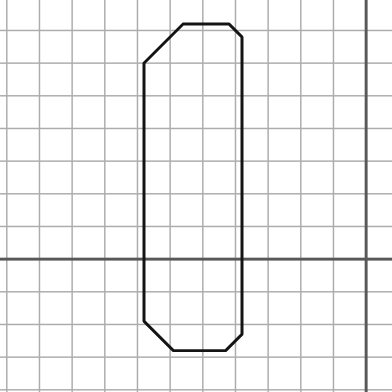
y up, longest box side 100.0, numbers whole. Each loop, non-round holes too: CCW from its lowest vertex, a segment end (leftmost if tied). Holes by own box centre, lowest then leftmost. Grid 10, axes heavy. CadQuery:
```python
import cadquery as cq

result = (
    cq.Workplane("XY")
    .moveTo(-59.0, -28.0)
    .lineTo(-43.0, -28.0)
    .lineTo(-38.0, -23.0)
    .lineTo(-38.0, 68.0)
    .lineTo(-42.0, 72.0)
    .lineTo(-56.0, 72.0)
    .lineTo(-68.0, 60.0)
    .lineTo(-68.0, -19.0)
    .close()
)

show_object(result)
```